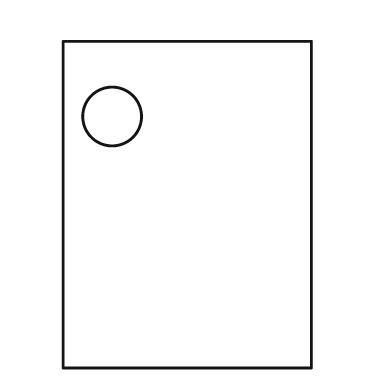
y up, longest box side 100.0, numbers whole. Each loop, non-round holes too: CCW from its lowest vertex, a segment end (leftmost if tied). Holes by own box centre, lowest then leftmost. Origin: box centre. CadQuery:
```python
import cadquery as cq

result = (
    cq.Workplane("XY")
    .moveTo(-38.0, -50.0)
    .lineTo(38.0, -50.0)
    .lineTo(38.0, 50.0)
    .lineTo(-38.0, 50.0)
    .close()
    .moveTo(-23.0, 27.0)
    .circle(9.0)
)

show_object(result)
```